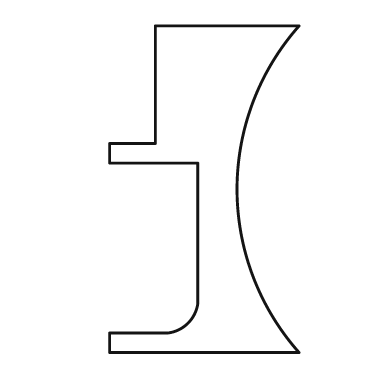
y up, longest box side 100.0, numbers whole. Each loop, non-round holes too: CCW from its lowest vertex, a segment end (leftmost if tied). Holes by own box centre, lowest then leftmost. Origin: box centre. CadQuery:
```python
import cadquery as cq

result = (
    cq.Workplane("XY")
    .moveTo(-29.0, -50.0)
    .lineTo(29.0, -50.0)
    .threePointArc((10.0, 0.0), (29.0, 50.0))
    .lineTo(-15.0, 50.0)
    .lineTo(-15.0, 14.0)
    .lineTo(-29.0, 14.0)
    .lineTo(-29.0, 8.0)
    .lineTo(-2.0, 8.0)
    .lineTo(-2.0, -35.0)
    .threePointArc((-5.0, -41.0), (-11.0, -44.0))
    .lineTo(-29.0, -44.0)
    .close()
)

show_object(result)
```